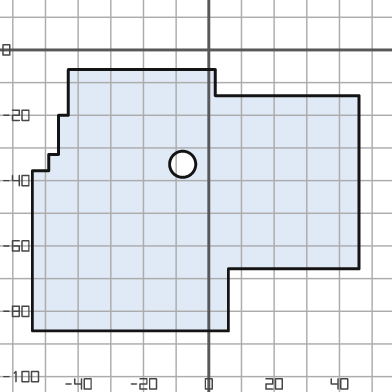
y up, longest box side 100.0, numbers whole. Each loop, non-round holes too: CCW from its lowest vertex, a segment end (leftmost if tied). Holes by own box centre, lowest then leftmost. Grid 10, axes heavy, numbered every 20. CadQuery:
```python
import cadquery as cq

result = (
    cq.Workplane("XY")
    .moveTo(-54.0, -86.0)
    .lineTo(6.0, -86.0)
    .lineTo(6.0, -67.0)
    .lineTo(46.0, -67.0)
    .lineTo(46.0, -14.0)
    .lineTo(2.0, -14.0)
    .lineTo(2.0, -6.0)
    .lineTo(-43.0, -6.0)
    .lineTo(-43.0, -20.0)
    .lineTo(-46.0, -20.0)
    .lineTo(-46.0, -32.0)
    .lineTo(-49.0, -32.0)
    .lineTo(-49.0, -37.0)
    .lineTo(-54.0, -37.0)
    .close()
    .moveTo(-8.0, -35.0)
    .circle(4.0)
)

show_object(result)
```